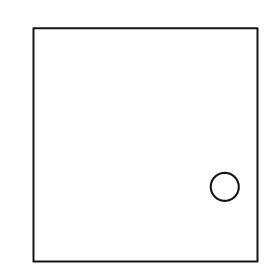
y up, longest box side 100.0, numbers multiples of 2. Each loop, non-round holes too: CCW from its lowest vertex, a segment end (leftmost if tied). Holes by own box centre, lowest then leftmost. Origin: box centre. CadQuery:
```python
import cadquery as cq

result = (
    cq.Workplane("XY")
    .moveTo(-48.0, -50.0)
    .lineTo(48.0, -50.0)
    .lineTo(48.0, 50.0)
    .lineTo(-48.0, 50.0)
    .close()
    .moveTo(34.0, -18.0)
    .circle(6.0)
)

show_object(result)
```